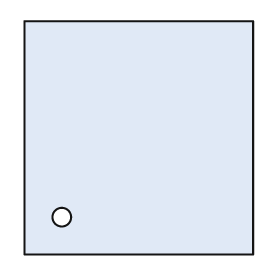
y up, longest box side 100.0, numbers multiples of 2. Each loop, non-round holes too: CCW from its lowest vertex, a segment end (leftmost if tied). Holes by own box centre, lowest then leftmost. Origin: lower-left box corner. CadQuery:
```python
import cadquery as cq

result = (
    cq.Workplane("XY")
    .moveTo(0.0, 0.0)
    .lineTo(98.0, 0.0)
    .lineTo(98.0, 100.0)
    .lineTo(0.0, 100.0)
    .close()
    .moveTo(16.0, 16.0)
    .circle(4.0)
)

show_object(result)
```